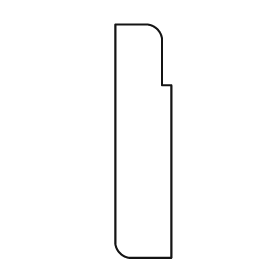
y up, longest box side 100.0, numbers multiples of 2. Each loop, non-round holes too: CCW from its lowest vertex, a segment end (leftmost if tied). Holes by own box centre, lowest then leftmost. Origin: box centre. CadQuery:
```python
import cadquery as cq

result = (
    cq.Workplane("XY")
    .moveTo(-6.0, -50.0)
    .lineTo(12.0, -50.0)
    .lineTo(12.0, 24.0)
    .lineTo(8.0, 24.0)
    .lineTo(8.0, 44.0)
    .threePointArc((6.0, 48.0), (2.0, 50.0))
    .lineTo(-12.0, 50.0)
    .lineTo(-12.0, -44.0)
    .threePointArc((-10.0, -48.0), (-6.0, -50.0))
    .close()
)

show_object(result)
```